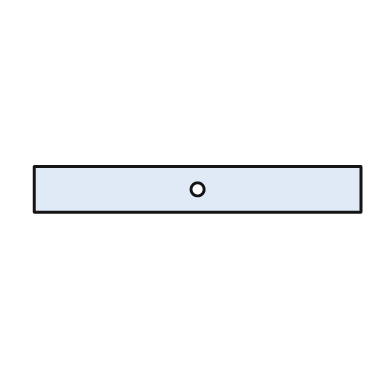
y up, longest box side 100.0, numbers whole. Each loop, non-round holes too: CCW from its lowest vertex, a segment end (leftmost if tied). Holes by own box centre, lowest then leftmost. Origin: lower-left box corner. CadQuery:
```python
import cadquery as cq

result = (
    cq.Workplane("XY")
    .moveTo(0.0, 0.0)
    .lineTo(100.0, 0.0)
    .lineTo(100.0, 14.0)
    .lineTo(0.0, 14.0)
    .close()
    .moveTo(50.0, 7.0)
    .circle(2.0)
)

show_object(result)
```